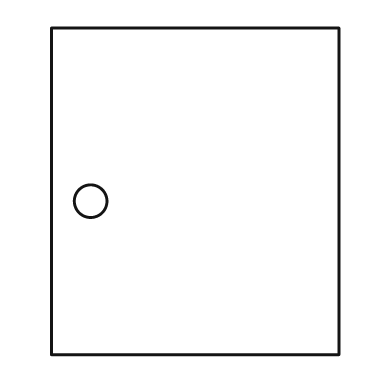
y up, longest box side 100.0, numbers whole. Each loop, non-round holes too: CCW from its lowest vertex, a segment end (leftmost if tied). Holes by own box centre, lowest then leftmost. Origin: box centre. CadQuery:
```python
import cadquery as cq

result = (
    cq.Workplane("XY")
    .moveTo(-44.0, -50.0)
    .lineTo(44.0, -50.0)
    .lineTo(44.0, 50.0)
    .lineTo(-44.0, 50.0)
    .close()
    .moveTo(-32.0, -3.0)
    .circle(5.0)
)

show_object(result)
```